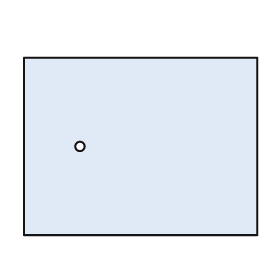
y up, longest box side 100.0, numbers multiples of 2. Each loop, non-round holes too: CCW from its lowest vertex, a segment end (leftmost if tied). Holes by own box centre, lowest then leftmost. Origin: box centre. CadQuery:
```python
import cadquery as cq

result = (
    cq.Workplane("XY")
    .moveTo(-50.0, -38.0)
    .lineTo(50.0, -38.0)
    .lineTo(50.0, 38.0)
    .lineTo(-50.0, 38.0)
    .close()
    .moveTo(-26.0, 0.0)
    .circle(2.0)
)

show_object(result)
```